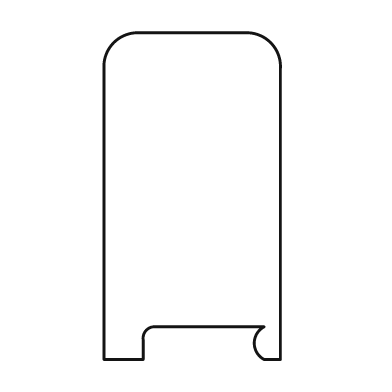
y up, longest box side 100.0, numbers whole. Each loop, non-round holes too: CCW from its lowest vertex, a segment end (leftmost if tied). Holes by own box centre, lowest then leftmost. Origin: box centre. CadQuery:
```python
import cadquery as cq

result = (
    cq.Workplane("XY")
    .moveTo(-27.0, -50.0)
    .lineTo(-15.0, -50.0)
    .lineTo(-15.0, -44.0)
    .threePointArc((-14.0, -41.0), (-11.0, -40.0))
    .lineTo(22.0, -40.0)
    .threePointArc((19.0, -45.0), (22.0, -50.0))
    .lineTo(27.0, -50.0)
    .lineTo(27.0, 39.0)
    .threePointArc((24.0, 47.0), (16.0, 50.0))
    .lineTo(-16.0, 50.0)
    .threePointArc((-24.0, 47.0), (-27.0, 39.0))
    .close()
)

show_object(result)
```